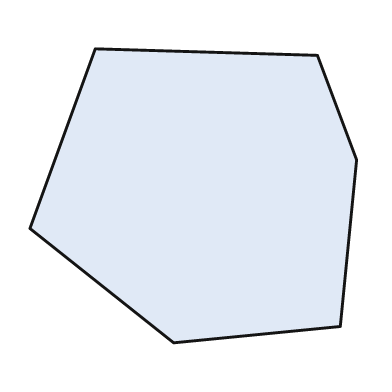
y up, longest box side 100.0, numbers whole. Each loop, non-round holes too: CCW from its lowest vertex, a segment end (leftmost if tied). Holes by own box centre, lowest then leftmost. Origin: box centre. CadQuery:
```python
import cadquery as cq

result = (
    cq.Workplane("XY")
    .moveTo(-6.0, -45.0)
    .lineTo(45.0, -40.0)
    .lineTo(50.0, 11.0)
    .lineTo(38.0, 43.0)
    .lineTo(-30.0, 45.0)
    .lineTo(-50.0, -10.0)
    .close()
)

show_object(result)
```